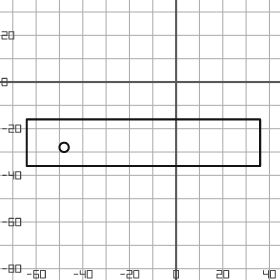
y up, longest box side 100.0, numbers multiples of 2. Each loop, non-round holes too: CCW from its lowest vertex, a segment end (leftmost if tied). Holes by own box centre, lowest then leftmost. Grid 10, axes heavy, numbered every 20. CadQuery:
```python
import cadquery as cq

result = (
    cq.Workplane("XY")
    .moveTo(-64.0, -36.0)
    .lineTo(36.0, -36.0)
    .lineTo(36.0, -16.0)
    .lineTo(-64.0, -16.0)
    .close()
    .moveTo(-48.0, -28.0)
    .circle(2.0)
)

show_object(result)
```